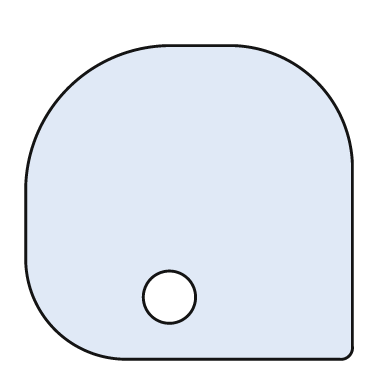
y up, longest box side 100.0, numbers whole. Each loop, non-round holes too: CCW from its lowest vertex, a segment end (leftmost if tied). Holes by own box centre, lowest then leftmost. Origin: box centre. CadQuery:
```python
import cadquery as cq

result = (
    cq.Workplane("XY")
    .moveTo(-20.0, -48.0)
    .lineTo(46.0, -48.0)
    .threePointArc((49.0, -47.0), (50.0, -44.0))
    .lineTo(50.0, 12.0)
    .threePointArc((39.0, 37.0), (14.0, 48.0))
    .lineTo(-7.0, 48.0)
    .threePointArc((-37.0, 35.0), (-50.0, 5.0))
    .lineTo(-50.0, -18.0)
    .threePointArc((-41.0, -39.0), (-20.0, -48.0))
    .close()
    .moveTo(-6.0, -29.0)
    .circle(8.0)
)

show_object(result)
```